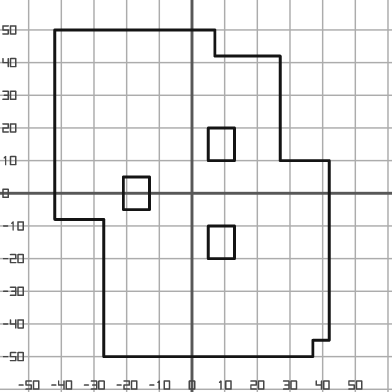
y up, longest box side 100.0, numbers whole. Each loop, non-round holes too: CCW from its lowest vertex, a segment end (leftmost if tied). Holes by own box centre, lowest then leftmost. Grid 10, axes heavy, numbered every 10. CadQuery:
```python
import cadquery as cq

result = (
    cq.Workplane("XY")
    .moveTo(-27.0, -50.0)
    .lineTo(37.0, -50.0)
    .lineTo(37.0, -45.0)
    .lineTo(42.0, -45.0)
    .lineTo(42.0, 10.0)
    .lineTo(27.0, 10.0)
    .lineTo(27.0, 42.0)
    .lineTo(7.0, 42.0)
    .lineTo(7.0, 50.0)
    .lineTo(-42.0, 50.0)
    .lineTo(-42.0, -8.0)
    .lineTo(-27.0, -8.0)
    .close()
    .moveTo(5.0, -20.0)
    .lineTo(13.0, -20.0)
    .lineTo(13.0, -10.0)
    .lineTo(5.0, -10.0)
    .close()
    .moveTo(-21.0, -5.0)
    .lineTo(-13.0, -5.0)
    .lineTo(-13.0, 5.0)
    .lineTo(-21.0, 5.0)
    .close()
    .moveTo(5.0, 10.0)
    .lineTo(13.0, 10.0)
    .lineTo(13.0, 20.0)
    .lineTo(5.0, 20.0)
    .close()
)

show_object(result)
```